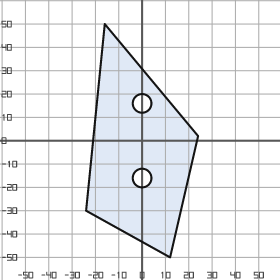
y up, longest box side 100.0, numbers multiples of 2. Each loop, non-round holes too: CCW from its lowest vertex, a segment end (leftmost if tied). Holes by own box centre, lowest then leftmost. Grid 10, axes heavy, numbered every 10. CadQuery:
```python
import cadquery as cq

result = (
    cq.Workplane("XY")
    .moveTo(12.0, -50.0)
    .lineTo(24.0, 2.0)
    .lineTo(-16.0, 50.0)
    .lineTo(-24.0, -30.0)
    .close()
    .moveTo(0.0, -16.0)
    .circle(4.0)
    .moveTo(0.0, 16.0)
    .circle(4.0)
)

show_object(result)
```